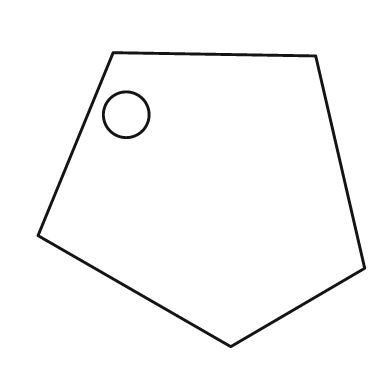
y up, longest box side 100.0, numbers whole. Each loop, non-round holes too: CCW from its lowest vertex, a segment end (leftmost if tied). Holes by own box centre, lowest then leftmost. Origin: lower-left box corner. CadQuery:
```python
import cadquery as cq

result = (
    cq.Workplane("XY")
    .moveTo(59.0, 0.0)
    .lineTo(100.0, 24.0)
    .lineTo(85.0, 89.0)
    .lineTo(23.0, 90.0)
    .lineTo(0.0, 34.0)
    .close()
    .moveTo(27.0, 71.0)
    .circle(7.0)
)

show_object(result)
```